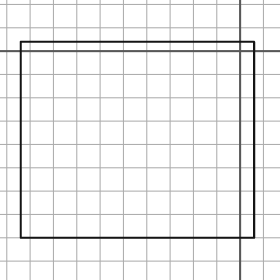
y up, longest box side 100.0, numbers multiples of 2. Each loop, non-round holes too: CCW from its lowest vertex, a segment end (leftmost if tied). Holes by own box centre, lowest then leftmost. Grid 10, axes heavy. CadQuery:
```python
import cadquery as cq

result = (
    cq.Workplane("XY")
    .moveTo(-94.0, -80.0)
    .lineTo(6.0, -80.0)
    .lineTo(6.0, 4.0)
    .lineTo(-94.0, 4.0)
    .close()
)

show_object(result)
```